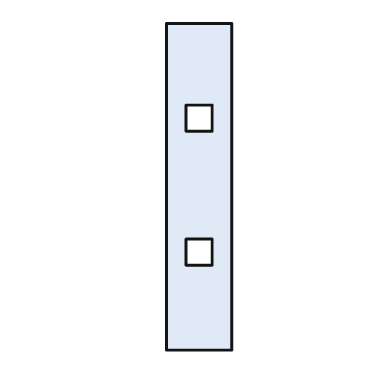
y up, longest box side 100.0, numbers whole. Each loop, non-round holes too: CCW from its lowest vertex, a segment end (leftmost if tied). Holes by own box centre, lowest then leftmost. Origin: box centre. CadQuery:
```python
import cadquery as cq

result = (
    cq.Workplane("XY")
    .moveTo(-10.0, -50.0)
    .lineTo(10.0, -50.0)
    .lineTo(10.0, 50.0)
    .lineTo(-10.0, 50.0)
    .close()
    .moveTo(-4.0, -24.0)
    .lineTo(4.0, -24.0)
    .lineTo(4.0, -16.0)
    .lineTo(-4.0, -16.0)
    .close()
    .moveTo(-4.0, 17.0)
    .lineTo(4.0, 17.0)
    .lineTo(4.0, 25.0)
    .lineTo(-4.0, 25.0)
    .close()
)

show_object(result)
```